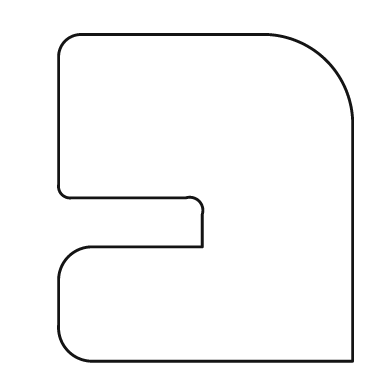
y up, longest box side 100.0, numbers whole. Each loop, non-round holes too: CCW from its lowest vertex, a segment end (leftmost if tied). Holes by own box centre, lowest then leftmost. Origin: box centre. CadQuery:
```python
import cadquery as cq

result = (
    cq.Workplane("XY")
    .moveTo(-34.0, -50.0)
    .lineTo(45.0, -50.0)
    .lineTo(45.0, 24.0)
    .threePointArc((37.0, 42.0), (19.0, 50.0))
    .lineTo(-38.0, 50.0)
    .threePointArc((-43.0, 48.0), (-45.0, 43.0))
    .lineTo(-45.0, 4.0)
    .threePointArc((-44.0, 1.0), (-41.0, 0.0))
    .lineTo(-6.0, 0.0)
    .threePointArc((-2.0, -1.0), (-1.0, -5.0))
    .lineTo(-1.0, -15.0)
    .lineTo(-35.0, -15.0)
    .threePointArc((-42.0, -18.0), (-45.0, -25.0))
    .lineTo(-45.0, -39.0)
    .threePointArc((-42.0, -47.0), (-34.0, -50.0))
    .close()
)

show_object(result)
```